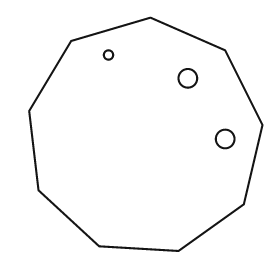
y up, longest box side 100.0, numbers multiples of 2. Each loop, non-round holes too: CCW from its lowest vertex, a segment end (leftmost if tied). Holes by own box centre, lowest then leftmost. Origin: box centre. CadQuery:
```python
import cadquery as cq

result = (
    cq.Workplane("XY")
    .moveTo(14.0, -50.0)
    .lineTo(42.0, -30.0)
    .lineTo(50.0, 4.0)
    .lineTo(34.0, 36.0)
    .lineTo(2.0, 50.0)
    .lineTo(-32.0, 40.0)
    .lineTo(-50.0, 10.0)
    .lineTo(-46.0, -24.0)
    .lineTo(-20.0, -48.0)
    .close()
    .moveTo(34.0, -2.0)
    .circle(4.0)
    .moveTo(18.0, 24.0)
    .circle(4.0)
    .moveTo(-16.0, 34.0)
    .circle(2.0)
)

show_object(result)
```